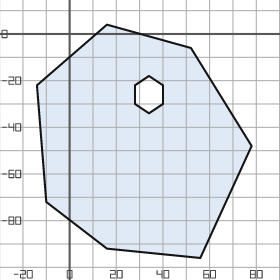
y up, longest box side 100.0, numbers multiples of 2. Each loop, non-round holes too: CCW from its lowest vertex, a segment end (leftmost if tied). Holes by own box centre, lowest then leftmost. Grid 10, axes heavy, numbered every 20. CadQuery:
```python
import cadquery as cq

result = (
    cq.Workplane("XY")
    .moveTo(56.0, -96.0)
    .lineTo(78.0, -48.0)
    .lineTo(52.0, -6.0)
    .lineTo(16.0, 4.0)
    .lineTo(-14.0, -22.0)
    .lineTo(-10.0, -72.0)
    .lineTo(16.0, -92.0)
    .close()
    .moveTo(34.0, -34.0)
    .lineTo(40.0, -30.0)
    .lineTo(40.0, -22.0)
    .lineTo(34.0, -18.0)
    .lineTo(28.0, -22.0)
    .lineTo(28.0, -30.0)
    .close()
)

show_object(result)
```